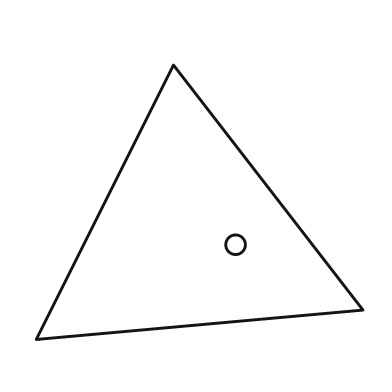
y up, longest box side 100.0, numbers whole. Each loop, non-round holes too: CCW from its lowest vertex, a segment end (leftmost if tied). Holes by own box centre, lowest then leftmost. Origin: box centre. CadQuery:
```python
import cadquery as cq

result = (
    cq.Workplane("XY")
    .moveTo(-50.0, -42.0)
    .lineTo(50.0, -33.0)
    .lineTo(-8.0, 42.0)
    .close()
    .moveTo(11.0, -13.0)
    .circle(3.0)
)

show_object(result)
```